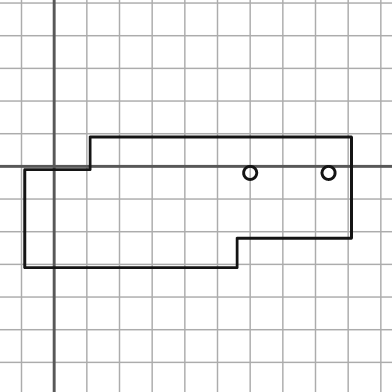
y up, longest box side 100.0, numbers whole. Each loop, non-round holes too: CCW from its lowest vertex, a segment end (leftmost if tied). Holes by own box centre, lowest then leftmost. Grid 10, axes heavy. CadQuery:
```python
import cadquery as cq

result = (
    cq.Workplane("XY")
    .moveTo(-9.0, -31.0)
    .lineTo(56.0, -31.0)
    .lineTo(56.0, -22.0)
    .lineTo(91.0, -22.0)
    .lineTo(91.0, 9.0)
    .lineTo(11.0, 9.0)
    .lineTo(11.0, -1.0)
    .lineTo(-9.0, -1.0)
    .close()
    .moveTo(60.0, -2.0)
    .circle(2.0)
    .moveTo(84.0, -2.0)
    .circle(2.0)
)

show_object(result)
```